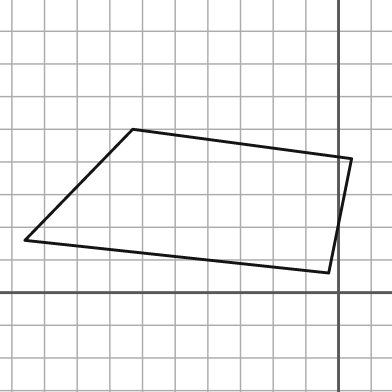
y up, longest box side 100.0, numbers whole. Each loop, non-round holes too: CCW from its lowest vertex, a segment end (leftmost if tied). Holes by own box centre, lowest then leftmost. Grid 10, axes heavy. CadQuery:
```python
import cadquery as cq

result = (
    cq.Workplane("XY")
    .moveTo(-3.0, 6.0)
    .lineTo(4.0, 41.0)
    .lineTo(-63.0, 50.0)
    .lineTo(-96.0, 16.0)
    .close()
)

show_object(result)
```